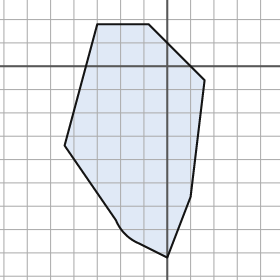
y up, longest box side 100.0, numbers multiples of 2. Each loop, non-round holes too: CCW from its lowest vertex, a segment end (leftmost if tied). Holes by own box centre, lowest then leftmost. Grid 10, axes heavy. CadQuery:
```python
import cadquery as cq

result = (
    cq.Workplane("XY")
    .moveTo(0.0, -82.0)
    .lineTo(10.0, -56.0)
    .lineTo(16.0, -6.0)
    .lineTo(-8.0, 18.0)
    .lineTo(-30.0, 18.0)
    .lineTo(-44.0, -34.0)
    .lineTo(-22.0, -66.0)
    .threePointArc((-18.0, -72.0), (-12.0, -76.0))
    .close()
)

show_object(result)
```